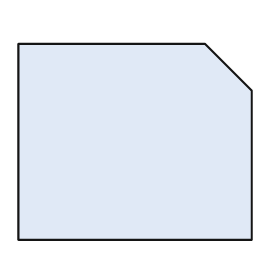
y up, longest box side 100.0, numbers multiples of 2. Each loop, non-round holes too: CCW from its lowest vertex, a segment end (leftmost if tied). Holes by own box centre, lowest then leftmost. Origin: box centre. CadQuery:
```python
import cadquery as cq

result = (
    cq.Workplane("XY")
    .moveTo(-50.0, -42.0)
    .lineTo(50.0, -42.0)
    .lineTo(50.0, 22.0)
    .lineTo(30.0, 42.0)
    .lineTo(-50.0, 42.0)
    .close()
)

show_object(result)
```